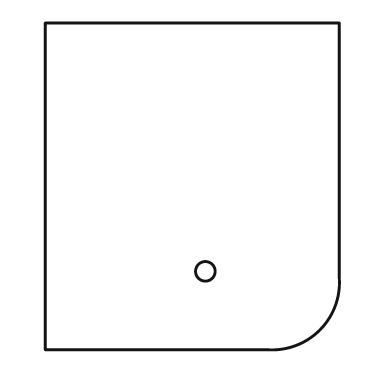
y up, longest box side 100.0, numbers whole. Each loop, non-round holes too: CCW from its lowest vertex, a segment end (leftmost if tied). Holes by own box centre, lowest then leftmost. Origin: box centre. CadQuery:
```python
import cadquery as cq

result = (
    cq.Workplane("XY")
    .moveTo(-45.0, -50.0)
    .lineTo(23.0, -50.0)
    .threePointArc((39.0, -44.0), (45.0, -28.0))
    .lineTo(45.0, 50.0)
    .lineTo(-45.0, 50.0)
    .close()
    .moveTo(4.0, -26.0)
    .circle(3.0)
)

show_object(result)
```